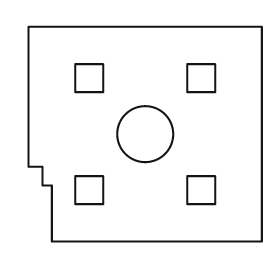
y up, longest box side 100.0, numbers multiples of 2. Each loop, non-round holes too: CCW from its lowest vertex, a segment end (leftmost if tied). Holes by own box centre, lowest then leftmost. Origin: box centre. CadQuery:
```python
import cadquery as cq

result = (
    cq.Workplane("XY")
    .moveTo(-40.0, -46.0)
    .lineTo(50.0, -46.0)
    .lineTo(50.0, 46.0)
    .lineTo(-50.0, 46.0)
    .lineTo(-50.0, -14.0)
    .lineTo(-44.0, -14.0)
    .lineTo(-44.0, -22.0)
    .lineTo(-40.0, -22.0)
    .close()
    .moveTo(-30.0, -30.0)
    .lineTo(-18.0, -30.0)
    .lineTo(-18.0, -18.0)
    .lineTo(-30.0, -18.0)
    .close()
    .moveTo(18.0, -30.0)
    .lineTo(30.0, -30.0)
    .lineTo(30.0, -18.0)
    .lineTo(18.0, -18.0)
    .close()
    .moveTo(0.0, 0.0)
    .circle(12.0)
    .moveTo(-30.0, 18.0)
    .lineTo(-18.0, 18.0)
    .lineTo(-18.0, 30.0)
    .lineTo(-30.0, 30.0)
    .close()
    .moveTo(18.0, 18.0)
    .lineTo(30.0, 18.0)
    .lineTo(30.0, 30.0)
    .lineTo(18.0, 30.0)
    .close()
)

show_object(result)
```